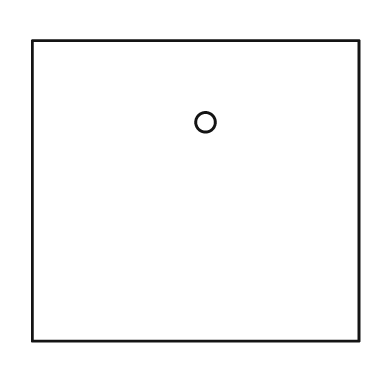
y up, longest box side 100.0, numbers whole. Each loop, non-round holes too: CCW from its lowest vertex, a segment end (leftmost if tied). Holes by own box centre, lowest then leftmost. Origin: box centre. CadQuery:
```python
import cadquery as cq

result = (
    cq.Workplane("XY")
    .moveTo(-50.0, -46.0)
    .lineTo(50.0, -46.0)
    .lineTo(50.0, 46.0)
    .lineTo(-50.0, 46.0)
    .close()
    .moveTo(3.0, 21.0)
    .circle(3.0)
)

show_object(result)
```